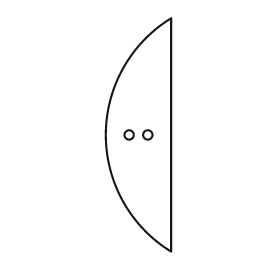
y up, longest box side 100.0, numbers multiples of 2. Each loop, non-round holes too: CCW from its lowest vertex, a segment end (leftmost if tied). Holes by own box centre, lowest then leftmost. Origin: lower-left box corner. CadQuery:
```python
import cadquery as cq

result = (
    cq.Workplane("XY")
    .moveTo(28.0, 0.0)
    .lineTo(28.0, 100.0)
    .threePointArc((0.0, 50.0), (28.0, 0.0))
    .close()
    .moveTo(10.0, 50.0)
    .circle(2.0)
    .moveTo(18.0, 50.0)
    .circle(2.0)
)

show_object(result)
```